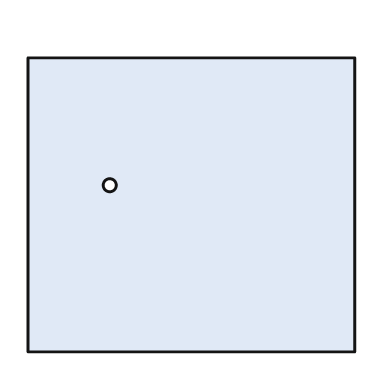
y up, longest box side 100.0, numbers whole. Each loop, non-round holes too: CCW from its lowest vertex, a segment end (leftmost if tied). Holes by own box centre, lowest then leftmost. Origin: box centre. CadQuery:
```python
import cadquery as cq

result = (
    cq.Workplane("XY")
    .moveTo(-50.0, -45.0)
    .lineTo(50.0, -45.0)
    .lineTo(50.0, 45.0)
    .lineTo(-50.0, 45.0)
    .close()
    .moveTo(-25.0, 6.0)
    .circle(2.0)
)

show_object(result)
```